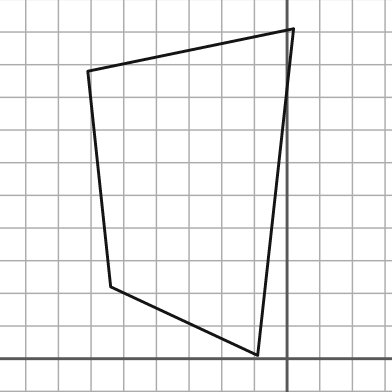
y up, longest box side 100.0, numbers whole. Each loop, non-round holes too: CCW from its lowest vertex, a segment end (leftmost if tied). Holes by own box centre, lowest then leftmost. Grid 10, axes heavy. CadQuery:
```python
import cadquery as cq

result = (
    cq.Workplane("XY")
    .moveTo(-9.0, 1.0)
    .lineTo(2.0, 101.0)
    .lineTo(-61.0, 88.0)
    .lineTo(-54.0, 22.0)
    .close()
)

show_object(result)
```